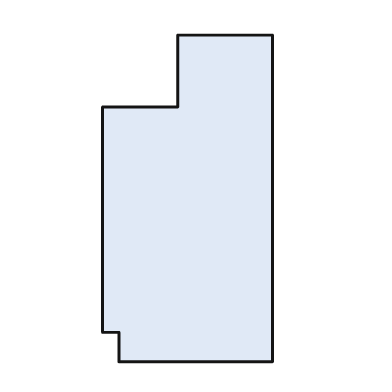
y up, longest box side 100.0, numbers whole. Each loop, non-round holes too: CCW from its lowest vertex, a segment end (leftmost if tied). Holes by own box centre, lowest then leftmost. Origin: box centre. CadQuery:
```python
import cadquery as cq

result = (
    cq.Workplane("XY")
    .moveTo(-21.0, -50.0)
    .lineTo(26.0, -50.0)
    .lineTo(26.0, 50.0)
    .lineTo(-3.0, 50.0)
    .lineTo(-3.0, 28.0)
    .lineTo(-26.0, 28.0)
    .lineTo(-26.0, -41.0)
    .lineTo(-21.0, -41.0)
    .close()
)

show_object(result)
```